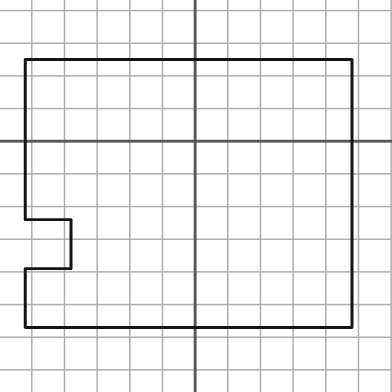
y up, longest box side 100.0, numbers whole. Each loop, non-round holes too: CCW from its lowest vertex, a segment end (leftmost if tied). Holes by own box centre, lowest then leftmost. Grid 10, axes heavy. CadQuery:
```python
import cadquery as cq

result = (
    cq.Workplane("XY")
    .moveTo(-52.0, -57.0)
    .lineTo(48.0, -57.0)
    .lineTo(48.0, 25.0)
    .lineTo(-52.0, 25.0)
    .lineTo(-52.0, -24.0)
    .lineTo(-38.0, -24.0)
    .lineTo(-38.0, -39.0)
    .lineTo(-52.0, -39.0)
    .close()
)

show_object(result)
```